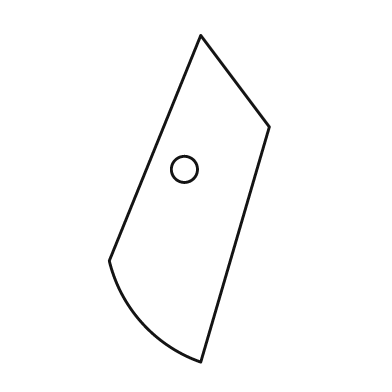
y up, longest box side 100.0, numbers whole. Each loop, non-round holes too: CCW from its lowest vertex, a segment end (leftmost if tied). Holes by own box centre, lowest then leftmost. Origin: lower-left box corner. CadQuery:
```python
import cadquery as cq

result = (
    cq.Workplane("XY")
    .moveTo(28.0, 0.0)
    .lineTo(49.0, 72.0)
    .lineTo(28.0, 100.0)
    .lineTo(0.0, 31.0)
    .threePointArc((10.0, 12.0), (28.0, 0.0))
    .close()
    .moveTo(23.0, 59.0)
    .circle(4.0)
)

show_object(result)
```